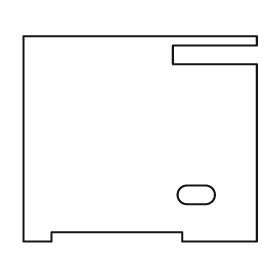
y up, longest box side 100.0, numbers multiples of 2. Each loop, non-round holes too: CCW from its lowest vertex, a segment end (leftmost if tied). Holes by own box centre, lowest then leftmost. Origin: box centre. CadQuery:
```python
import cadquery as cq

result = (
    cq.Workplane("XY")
    .moveTo(-50.0, -44.0)
    .lineTo(-38.0, -44.0)
    .lineTo(-38.0, -40.0)
    .lineTo(18.0, -40.0)
    .lineTo(18.0, -44.0)
    .lineTo(50.0, -44.0)
    .lineTo(50.0, 32.0)
    .lineTo(14.0, 32.0)
    .lineTo(14.0, 40.0)
    .lineTo(50.0, 40.0)
    .lineTo(50.0, 44.0)
    .lineTo(-50.0, 44.0)
    .close()
    .moveTo(20.0, -28.0)
    .lineTo(28.0, -28.0)
    .threePointArc((32.0, -24.0), (28.0, -20.0))
    .lineTo(20.0, -20.0)
    .threePointArc((16.0, -24.0), (20.0, -28.0))
    .close()
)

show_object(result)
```